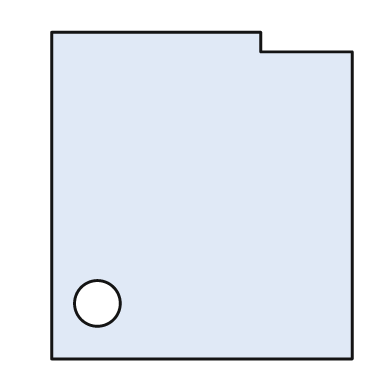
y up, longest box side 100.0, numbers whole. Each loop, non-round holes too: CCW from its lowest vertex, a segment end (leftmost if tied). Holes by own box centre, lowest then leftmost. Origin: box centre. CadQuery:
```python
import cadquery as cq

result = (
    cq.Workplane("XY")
    .moveTo(-46.0, -50.0)
    .lineTo(46.0, -50.0)
    .lineTo(46.0, 44.0)
    .lineTo(18.0, 44.0)
    .lineTo(18.0, 50.0)
    .lineTo(-46.0, 50.0)
    .close()
    .moveTo(-32.0, -33.0)
    .circle(7.0)
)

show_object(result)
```